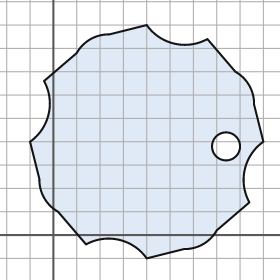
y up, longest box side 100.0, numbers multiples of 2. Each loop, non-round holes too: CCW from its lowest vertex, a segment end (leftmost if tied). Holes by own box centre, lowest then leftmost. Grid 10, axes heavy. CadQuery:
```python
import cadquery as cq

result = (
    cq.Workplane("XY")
    .moveTo(40.0, -10.0)
    .lineTo(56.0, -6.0)
    .threePointArc((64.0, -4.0), (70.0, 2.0))
    .lineTo(84.0, 14.0)
    .threePointArc((82.0, 28.0), (90.0, 40.0))
    .lineTo(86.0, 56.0)
    .threePointArc((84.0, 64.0), (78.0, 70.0))
    .lineTo(66.0, 84.0)
    .threePointArc((52.0, 82.0), (40.0, 90.0))
    .lineTo(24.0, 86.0)
    .threePointArc((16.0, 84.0), (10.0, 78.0))
    .lineTo(-4.0, 66.0)
    .threePointArc((-2.0, 52.0), (-10.0, 40.0))
    .lineTo(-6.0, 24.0)
    .threePointArc((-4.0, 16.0), (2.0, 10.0))
    .lineTo(14.0, -4.0)
    .threePointArc((28.0, -2.0), (40.0, -10.0))
    .close()
    .moveTo(74.0, 38.0)
    .circle(6.0)
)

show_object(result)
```